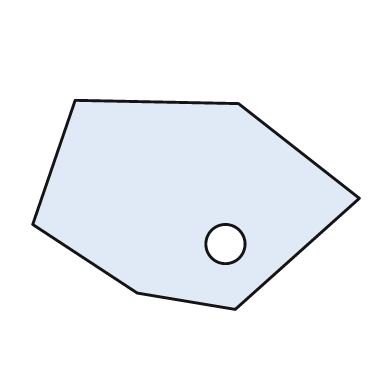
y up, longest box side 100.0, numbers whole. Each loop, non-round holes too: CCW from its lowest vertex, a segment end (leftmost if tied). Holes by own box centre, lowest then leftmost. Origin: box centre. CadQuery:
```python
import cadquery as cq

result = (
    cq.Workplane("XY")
    .moveTo(12.0, -32.0)
    .lineTo(50.0, 2.0)
    .lineTo(13.0, 31.0)
    .lineTo(-37.0, 32.0)
    .lineTo(-50.0, -6.0)
    .lineTo(-18.0, -27.0)
    .close()
    .moveTo(9.0, -12.0)
    .circle(6.0)
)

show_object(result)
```